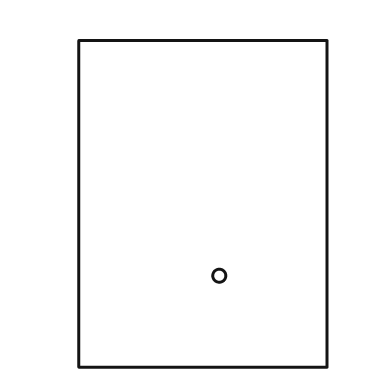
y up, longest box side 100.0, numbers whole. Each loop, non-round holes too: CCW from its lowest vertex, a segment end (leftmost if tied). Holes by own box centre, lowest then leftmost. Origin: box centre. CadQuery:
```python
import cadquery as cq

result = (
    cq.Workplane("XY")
    .moveTo(-38.0, -50.0)
    .lineTo(38.0, -50.0)
    .lineTo(38.0, 50.0)
    .lineTo(-38.0, 50.0)
    .close()
    .moveTo(5.0, -22.0)
    .circle(2.0)
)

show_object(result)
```